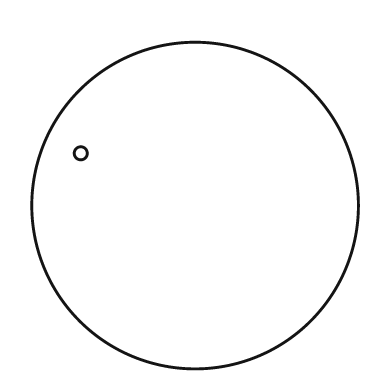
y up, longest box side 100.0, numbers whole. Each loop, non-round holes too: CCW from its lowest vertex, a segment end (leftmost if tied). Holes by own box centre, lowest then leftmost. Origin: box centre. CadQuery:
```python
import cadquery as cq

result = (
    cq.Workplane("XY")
    .moveTo(0.0, 0.0)
    .circle(50.0)
    .moveTo(-35.0, 16.0)
    .circle(2.0)
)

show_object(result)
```